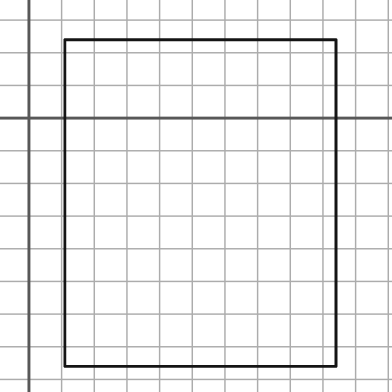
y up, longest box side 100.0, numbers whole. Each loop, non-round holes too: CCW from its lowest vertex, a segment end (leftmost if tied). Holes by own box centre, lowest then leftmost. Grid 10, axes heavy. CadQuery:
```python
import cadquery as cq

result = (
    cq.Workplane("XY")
    .moveTo(11.0, -76.0)
    .lineTo(94.0, -76.0)
    .lineTo(94.0, 24.0)
    .lineTo(11.0, 24.0)
    .close()
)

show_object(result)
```